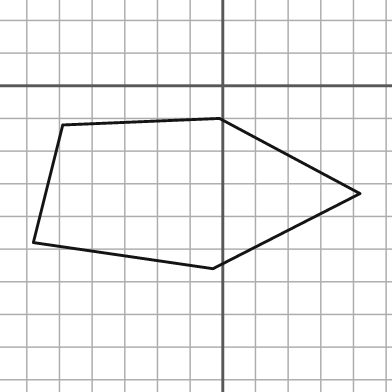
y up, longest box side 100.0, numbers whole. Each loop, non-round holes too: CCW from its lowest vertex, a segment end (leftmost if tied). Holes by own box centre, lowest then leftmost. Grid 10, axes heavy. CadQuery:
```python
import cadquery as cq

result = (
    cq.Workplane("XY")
    .moveTo(-3.0, -56.0)
    .lineTo(42.0, -33.0)
    .lineTo(-1.0, -10.0)
    .lineTo(-49.0, -12.0)
    .lineTo(-58.0, -48.0)
    .close()
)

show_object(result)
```